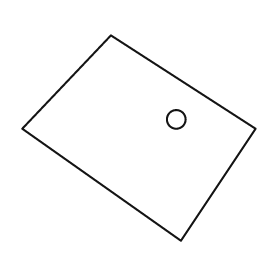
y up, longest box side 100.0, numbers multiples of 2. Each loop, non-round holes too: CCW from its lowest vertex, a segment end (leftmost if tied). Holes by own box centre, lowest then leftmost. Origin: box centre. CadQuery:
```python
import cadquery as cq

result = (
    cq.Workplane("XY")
    .moveTo(18.0, -44.0)
    .lineTo(50.0, 4.0)
    .lineTo(-12.0, 44.0)
    .lineTo(-50.0, 4.0)
    .close()
    .moveTo(16.0, 8.0)
    .circle(4.0)
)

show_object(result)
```